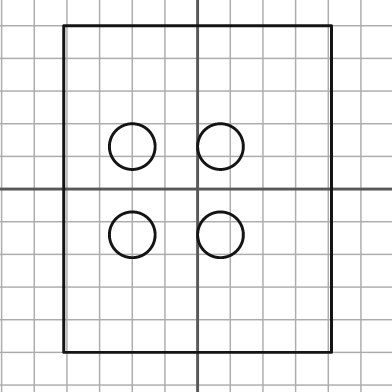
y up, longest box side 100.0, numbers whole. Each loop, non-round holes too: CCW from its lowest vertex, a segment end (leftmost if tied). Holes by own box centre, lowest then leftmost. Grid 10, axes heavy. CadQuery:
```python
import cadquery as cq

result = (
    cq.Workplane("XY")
    .moveTo(-41.0, -50.0)
    .lineTo(41.0, -50.0)
    .lineTo(41.0, 50.0)
    .lineTo(-41.0, 50.0)
    .close()
    .moveTo(-20.0, -14.0)
    .circle(7.0)
    .moveTo(7.0, -14.0)
    .circle(7.0)
    .moveTo(-20.0, 13.0)
    .circle(7.0)
    .moveTo(7.0, 13.0)
    .circle(7.0)
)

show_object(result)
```